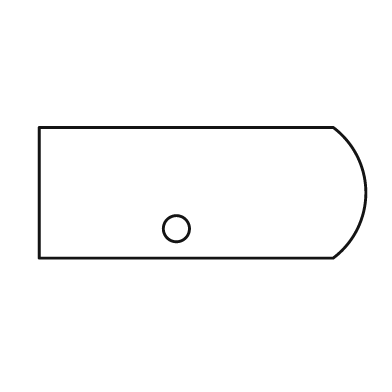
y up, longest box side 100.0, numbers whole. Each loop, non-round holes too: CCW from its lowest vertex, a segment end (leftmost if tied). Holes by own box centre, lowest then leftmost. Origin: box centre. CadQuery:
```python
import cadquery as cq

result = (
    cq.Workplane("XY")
    .moveTo(-50.0, -20.0)
    .lineTo(40.0, -20.0)
    .threePointArc((50.0, 0.0), (40.0, 20.0))
    .lineTo(-50.0, 20.0)
    .close()
    .moveTo(-8.0, -11.0)
    .circle(4.0)
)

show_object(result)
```